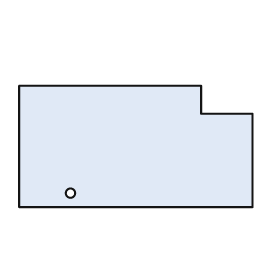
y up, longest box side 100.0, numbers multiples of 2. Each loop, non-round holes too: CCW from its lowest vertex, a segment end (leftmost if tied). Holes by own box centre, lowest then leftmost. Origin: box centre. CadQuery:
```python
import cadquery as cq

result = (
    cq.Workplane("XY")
    .moveTo(-50.0, -26.0)
    .lineTo(50.0, -26.0)
    .lineTo(50.0, 14.0)
    .lineTo(28.0, 14.0)
    .lineTo(28.0, 26.0)
    .lineTo(-50.0, 26.0)
    .close()
    .moveTo(-28.0, -20.0)
    .circle(2.0)
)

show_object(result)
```